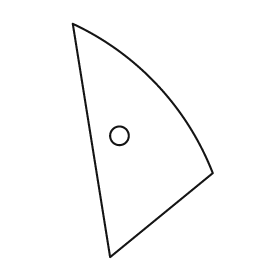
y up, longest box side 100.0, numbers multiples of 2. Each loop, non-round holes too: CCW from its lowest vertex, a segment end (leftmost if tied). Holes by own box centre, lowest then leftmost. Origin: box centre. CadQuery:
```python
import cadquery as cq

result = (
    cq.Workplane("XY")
    .moveTo(-14.0, -50.0)
    .lineTo(30.0, -14.0)
    .threePointArc((6.0, 24.0), (-30.0, 50.0))
    .close()
    .moveTo(-10.0, 2.0)
    .circle(4.0)
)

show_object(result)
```